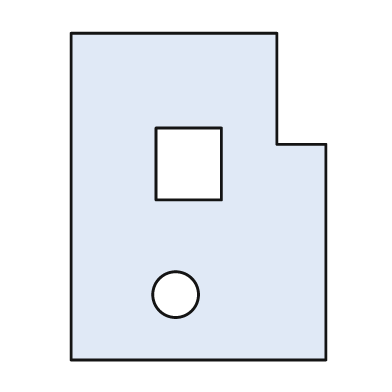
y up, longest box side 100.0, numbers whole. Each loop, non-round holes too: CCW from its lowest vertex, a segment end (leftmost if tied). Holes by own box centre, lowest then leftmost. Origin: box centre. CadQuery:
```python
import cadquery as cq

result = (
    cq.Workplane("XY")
    .moveTo(-39.0, -50.0)
    .lineTo(39.0, -50.0)
    .lineTo(39.0, 16.0)
    .lineTo(24.0, 16.0)
    .lineTo(24.0, 50.0)
    .lineTo(-39.0, 50.0)
    .close()
    .moveTo(-7.0, -30.0)
    .circle(7.0)
    .moveTo(-13.0, -1.0)
    .lineTo(7.0, -1.0)
    .lineTo(7.0, 21.0)
    .lineTo(-13.0, 21.0)
    .close()
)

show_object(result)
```